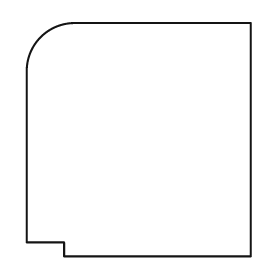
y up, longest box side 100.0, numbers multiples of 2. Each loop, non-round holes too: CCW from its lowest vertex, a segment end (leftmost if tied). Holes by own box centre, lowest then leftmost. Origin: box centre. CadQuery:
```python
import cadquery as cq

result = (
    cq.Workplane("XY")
    .moveTo(-32.0, -50.0)
    .lineTo(48.0, -50.0)
    .lineTo(48.0, 50.0)
    .lineTo(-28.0, 50.0)
    .threePointArc((-42.0, 44.0), (-48.0, 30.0))
    .lineTo(-48.0, -44.0)
    .lineTo(-32.0, -44.0)
    .close()
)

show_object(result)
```